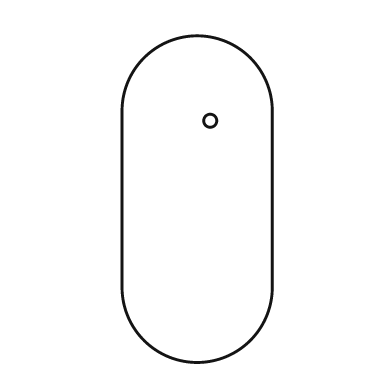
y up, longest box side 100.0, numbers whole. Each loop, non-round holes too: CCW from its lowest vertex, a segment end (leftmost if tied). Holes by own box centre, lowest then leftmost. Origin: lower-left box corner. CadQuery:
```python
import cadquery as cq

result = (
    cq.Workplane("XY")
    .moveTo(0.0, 23.0)
    .threePointArc((23.0, 0.0), (46.0, 23.0))
    .lineTo(46.0, 77.0)
    .threePointArc((23.0, 100.0), (0.0, 77.0))
    .close()
    .moveTo(27.0, 74.0)
    .circle(2.0)
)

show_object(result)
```